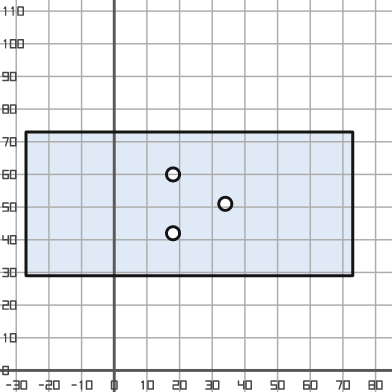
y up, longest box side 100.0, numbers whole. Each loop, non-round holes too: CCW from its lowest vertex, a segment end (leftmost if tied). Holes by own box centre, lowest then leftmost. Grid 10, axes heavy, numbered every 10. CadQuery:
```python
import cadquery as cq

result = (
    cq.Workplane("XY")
    .moveTo(-27.0, 29.0)
    .lineTo(73.0, 29.0)
    .lineTo(73.0, 73.0)
    .lineTo(-27.0, 73.0)
    .close()
    .moveTo(18.0, 42.0)
    .circle(2.0)
    .moveTo(34.0, 51.0)
    .circle(2.0)
    .moveTo(18.0, 60.0)
    .circle(2.0)
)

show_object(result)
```